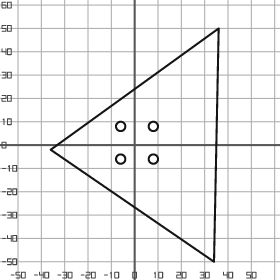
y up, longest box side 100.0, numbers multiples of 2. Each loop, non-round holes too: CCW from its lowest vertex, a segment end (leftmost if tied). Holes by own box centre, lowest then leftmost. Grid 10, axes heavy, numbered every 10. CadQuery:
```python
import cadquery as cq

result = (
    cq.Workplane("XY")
    .moveTo(34.0, -50.0)
    .lineTo(36.0, 50.0)
    .lineTo(-36.0, -2.0)
    .close()
    .moveTo(-6.0, -6.0)
    .circle(2.0)
    .moveTo(8.0, -6.0)
    .circle(2.0)
    .moveTo(-6.0, 8.0)
    .circle(2.0)
    .moveTo(8.0, 8.0)
    .circle(2.0)
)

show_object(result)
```